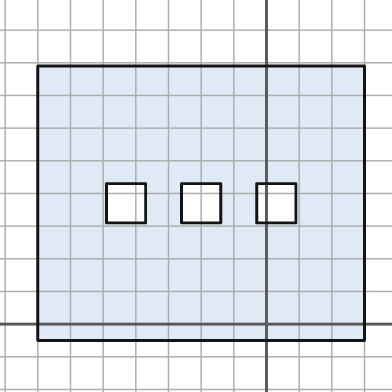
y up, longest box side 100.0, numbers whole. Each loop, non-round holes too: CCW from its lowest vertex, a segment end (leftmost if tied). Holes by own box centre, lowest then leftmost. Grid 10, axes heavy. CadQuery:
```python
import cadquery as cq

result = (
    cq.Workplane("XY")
    .moveTo(-70.0, -5.0)
    .lineTo(30.0, -5.0)
    .lineTo(30.0, 79.0)
    .lineTo(-70.0, 79.0)
    .close()
    .moveTo(-49.0, 31.0)
    .lineTo(-37.0, 31.0)
    .lineTo(-37.0, 43.0)
    .lineTo(-49.0, 43.0)
    .close()
    .moveTo(-26.0, 31.0)
    .lineTo(-14.0, 31.0)
    .lineTo(-14.0, 43.0)
    .lineTo(-26.0, 43.0)
    .close()
    .moveTo(-3.0, 31.0)
    .lineTo(9.0, 31.0)
    .lineTo(9.0, 43.0)
    .lineTo(-3.0, 43.0)
    .close()
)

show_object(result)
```